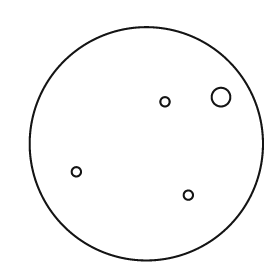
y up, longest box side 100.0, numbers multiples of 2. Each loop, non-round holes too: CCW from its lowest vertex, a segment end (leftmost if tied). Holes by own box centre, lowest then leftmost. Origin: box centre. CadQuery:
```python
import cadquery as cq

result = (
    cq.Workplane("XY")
    .moveTo(0.0, 0.0)
    .circle(50.0)
    .moveTo(18.0, -22.0)
    .circle(2.0)
    .moveTo(-30.0, -12.0)
    .circle(2.0)
    .moveTo(8.0, 18.0)
    .circle(2.0)
    .moveTo(32.0, 20.0)
    .circle(4.0)
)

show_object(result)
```